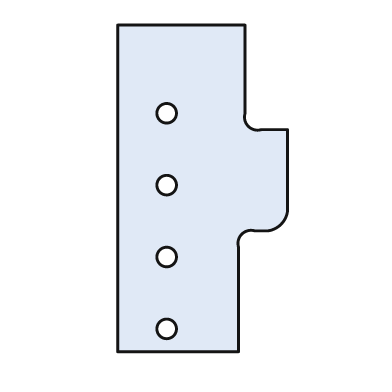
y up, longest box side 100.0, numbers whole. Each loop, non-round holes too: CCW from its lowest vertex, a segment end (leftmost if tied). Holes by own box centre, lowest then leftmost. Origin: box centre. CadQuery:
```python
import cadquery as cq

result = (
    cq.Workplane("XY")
    .moveTo(-26.0, -50.0)
    .lineTo(11.0, -50.0)
    .lineTo(11.0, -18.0)
    .threePointArc((12.0, -14.0), (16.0, -13.0))
    .lineTo(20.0, -13.0)
    .threePointArc((24.0, -11.0), (26.0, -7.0))
    .lineTo(26.0, 18.0)
    .lineTo(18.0, 18.0)
    .threePointArc((14.0, 19.0), (13.0, 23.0))
    .lineTo(13.0, 50.0)
    .lineTo(-26.0, 50.0)
    .close()
    .moveTo(-11.0, -43.0)
    .circle(3.0)
    .moveTo(-11.0, -21.0)
    .circle(3.0)
    .moveTo(-11.0, 1.0)
    .circle(3.0)
    .moveTo(-11.0, 23.0)
    .circle(3.0)
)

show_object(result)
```